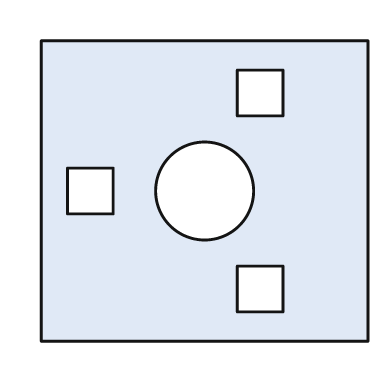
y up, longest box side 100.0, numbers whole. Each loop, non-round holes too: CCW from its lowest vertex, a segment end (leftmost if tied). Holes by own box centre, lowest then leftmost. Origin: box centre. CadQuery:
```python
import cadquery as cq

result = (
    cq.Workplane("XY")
    .moveTo(-50.0, -46.0)
    .lineTo(50.0, -46.0)
    .lineTo(50.0, 46.0)
    .lineTo(-50.0, 46.0)
    .close()
    .moveTo(10.0, -37.0)
    .lineTo(24.0, -37.0)
    .lineTo(24.0, -23.0)
    .lineTo(10.0, -23.0)
    .close()
    .moveTo(-42.0, -7.0)
    .lineTo(-28.0, -7.0)
    .lineTo(-28.0, 7.0)
    .lineTo(-42.0, 7.0)
    .close()
    .moveTo(0.0, 0.0)
    .circle(15.0)
    .moveTo(10.0, 23.0)
    .lineTo(24.0, 23.0)
    .lineTo(24.0, 37.0)
    .lineTo(10.0, 37.0)
    .close()
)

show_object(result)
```